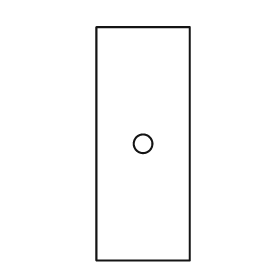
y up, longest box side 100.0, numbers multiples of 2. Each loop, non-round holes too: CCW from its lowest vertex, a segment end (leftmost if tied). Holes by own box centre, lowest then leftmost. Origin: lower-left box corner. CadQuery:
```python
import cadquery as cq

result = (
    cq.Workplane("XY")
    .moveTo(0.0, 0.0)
    .lineTo(40.0, 0.0)
    .lineTo(40.0, 100.0)
    .lineTo(0.0, 100.0)
    .close()
    .moveTo(20.0, 50.0)
    .circle(4.0)
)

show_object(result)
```